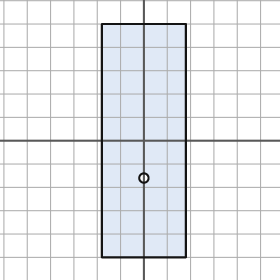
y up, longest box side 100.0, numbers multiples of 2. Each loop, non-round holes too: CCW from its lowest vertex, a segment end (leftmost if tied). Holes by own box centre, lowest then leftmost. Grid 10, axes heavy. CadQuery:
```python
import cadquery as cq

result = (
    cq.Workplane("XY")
    .moveTo(-18.0, -50.0)
    .lineTo(18.0, -50.0)
    .lineTo(18.0, 50.0)
    .lineTo(-18.0, 50.0)
    .close()
    .moveTo(0.0, -16.0)
    .circle(2.0)
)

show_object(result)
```